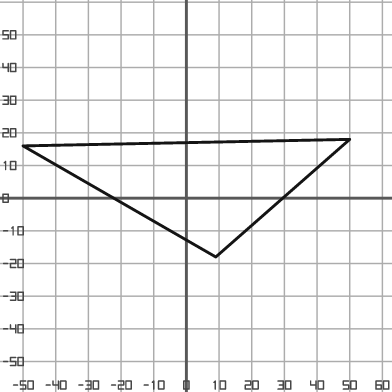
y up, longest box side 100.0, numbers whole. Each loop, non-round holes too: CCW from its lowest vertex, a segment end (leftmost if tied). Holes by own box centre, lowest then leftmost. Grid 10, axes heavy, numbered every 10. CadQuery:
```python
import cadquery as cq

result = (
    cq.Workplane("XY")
    .moveTo(9.0, -18.0)
    .lineTo(50.0, 18.0)
    .lineTo(-50.0, 16.0)
    .close()
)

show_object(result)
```